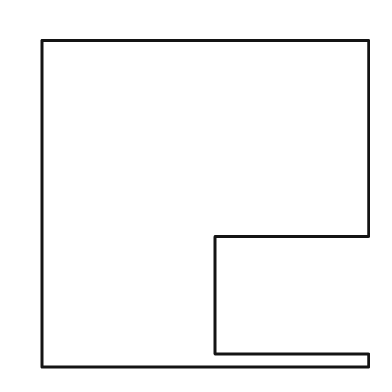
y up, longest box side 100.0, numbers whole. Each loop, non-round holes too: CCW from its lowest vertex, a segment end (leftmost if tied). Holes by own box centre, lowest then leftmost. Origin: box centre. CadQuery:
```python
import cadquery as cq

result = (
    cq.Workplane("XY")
    .moveTo(-50.0, -50.0)
    .lineTo(50.0, -50.0)
    .lineTo(50.0, -46.0)
    .lineTo(3.0, -46.0)
    .lineTo(3.0, -10.0)
    .lineTo(50.0, -10.0)
    .lineTo(50.0, 50.0)
    .lineTo(-50.0, 50.0)
    .close()
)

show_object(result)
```